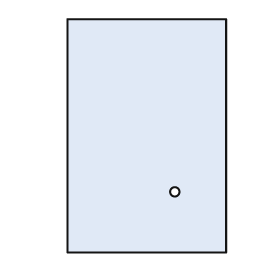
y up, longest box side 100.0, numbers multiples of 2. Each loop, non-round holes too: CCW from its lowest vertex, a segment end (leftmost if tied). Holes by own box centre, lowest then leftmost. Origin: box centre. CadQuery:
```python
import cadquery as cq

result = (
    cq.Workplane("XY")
    .moveTo(-34.0, -50.0)
    .lineTo(34.0, -50.0)
    .lineTo(34.0, 50.0)
    .lineTo(-34.0, 50.0)
    .close()
    .moveTo(12.0, -24.0)
    .circle(2.0)
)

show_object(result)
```